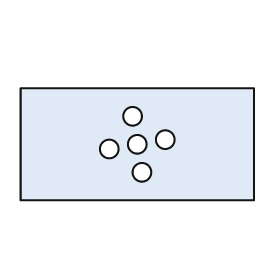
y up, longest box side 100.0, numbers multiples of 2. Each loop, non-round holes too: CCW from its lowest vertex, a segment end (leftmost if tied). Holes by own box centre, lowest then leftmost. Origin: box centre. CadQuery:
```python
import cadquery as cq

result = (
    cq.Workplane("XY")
    .moveTo(-50.0, -24.0)
    .lineTo(50.0, -24.0)
    .lineTo(50.0, 24.0)
    .lineTo(-50.0, 24.0)
    .close()
    .moveTo(2.0, -12.0)
    .circle(4.0)
    .moveTo(-12.0, -2.0)
    .circle(4.0)
    .moveTo(0.0, 0.0)
    .circle(4.0)
    .moveTo(12.0, 2.0)
    .circle(4.0)
    .moveTo(-2.0, 12.0)
    .circle(4.0)
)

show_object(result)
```